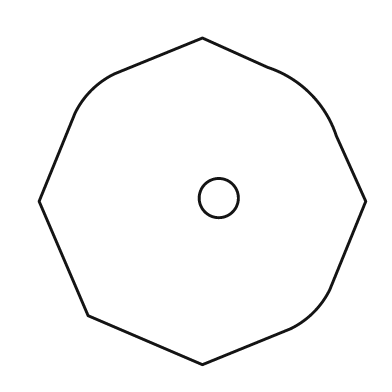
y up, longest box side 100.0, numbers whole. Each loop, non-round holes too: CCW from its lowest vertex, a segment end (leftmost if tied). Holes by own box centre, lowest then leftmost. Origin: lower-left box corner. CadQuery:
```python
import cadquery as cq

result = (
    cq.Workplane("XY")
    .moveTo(50.0, 0.0)
    .lineTo(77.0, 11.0)
    .threePointArc((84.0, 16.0), (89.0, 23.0))
    .lineTo(100.0, 50.0)
    .lineTo(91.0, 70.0)
    .threePointArc((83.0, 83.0), (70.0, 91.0))
    .lineTo(50.0, 100.0)
    .lineTo(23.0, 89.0)
    .threePointArc((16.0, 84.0), (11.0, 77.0))
    .lineTo(0.0, 50.0)
    .lineTo(15.0, 15.0)
    .close()
    .moveTo(55.0, 51.0)
    .circle(6.0)
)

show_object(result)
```